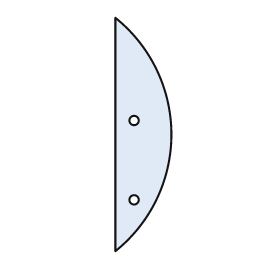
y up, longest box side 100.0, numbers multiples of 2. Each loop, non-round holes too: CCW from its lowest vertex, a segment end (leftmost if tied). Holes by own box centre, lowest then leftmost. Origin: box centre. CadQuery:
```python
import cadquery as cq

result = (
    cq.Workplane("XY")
    .moveTo(-12.0, -50.0)
    .threePointArc((12.0, 0.0), (-12.0, 50.0))
    .close()
    .moveTo(-4.0, -28.0)
    .circle(2.0)
    .moveTo(-4.0, 6.0)
    .circle(2.0)
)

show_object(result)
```